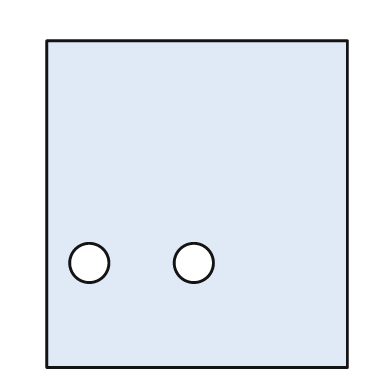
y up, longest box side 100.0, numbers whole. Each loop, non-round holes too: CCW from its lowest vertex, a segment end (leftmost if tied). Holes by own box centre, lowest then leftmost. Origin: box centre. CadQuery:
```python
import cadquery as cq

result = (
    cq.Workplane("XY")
    .moveTo(-46.0, -50.0)
    .lineTo(46.0, -50.0)
    .lineTo(46.0, 50.0)
    .lineTo(-46.0, 50.0)
    .close()
    .moveTo(-33.0, -18.0)
    .circle(6.0)
    .moveTo(-1.0, -18.0)
    .circle(6.0)
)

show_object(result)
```